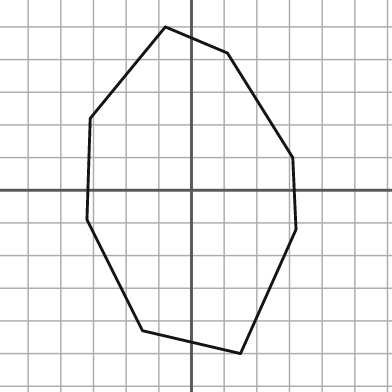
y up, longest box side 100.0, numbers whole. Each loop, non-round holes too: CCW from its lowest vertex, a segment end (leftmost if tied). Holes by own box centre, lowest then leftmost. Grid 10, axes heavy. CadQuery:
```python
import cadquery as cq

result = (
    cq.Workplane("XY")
    .moveTo(15.0, -50.0)
    .lineTo(32.0, -12.0)
    .lineTo(31.0, 10.0)
    .lineTo(11.0, 42.0)
    .lineTo(-8.0, 50.0)
    .lineTo(-31.0, 22.0)
    .lineTo(-32.0, -9.0)
    .lineTo(-15.0, -43.0)
    .close()
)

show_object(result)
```